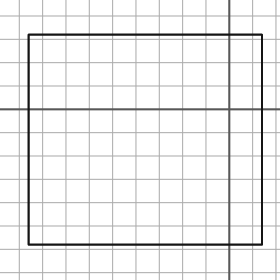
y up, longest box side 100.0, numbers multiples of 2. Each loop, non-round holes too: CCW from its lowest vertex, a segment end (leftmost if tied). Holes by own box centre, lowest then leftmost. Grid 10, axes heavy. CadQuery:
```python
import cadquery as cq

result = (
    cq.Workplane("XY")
    .moveTo(-86.0, -58.0)
    .lineTo(14.0, -58.0)
    .lineTo(14.0, 32.0)
    .lineTo(-86.0, 32.0)
    .close()
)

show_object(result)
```